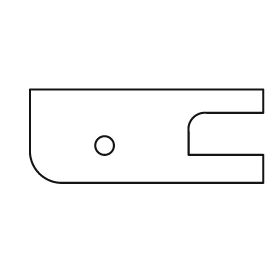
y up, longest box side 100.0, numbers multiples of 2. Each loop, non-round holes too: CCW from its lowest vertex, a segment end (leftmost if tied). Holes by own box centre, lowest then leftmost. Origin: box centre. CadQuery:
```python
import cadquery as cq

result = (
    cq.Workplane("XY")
    .moveTo(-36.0, -20.0)
    .lineTo(50.0, -20.0)
    .lineTo(50.0, -8.0)
    .lineTo(18.0, -8.0)
    .lineTo(18.0, 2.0)
    .threePointArc((20.0, 8.0), (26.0, 10.0))
    .lineTo(50.0, 10.0)
    .lineTo(50.0, 20.0)
    .lineTo(-50.0, 20.0)
    .lineTo(-50.0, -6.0)
    .threePointArc((-46.0, -16.0), (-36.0, -20.0))
    .close()
    .moveTo(-18.0, -4.0)
    .circle(4.0)
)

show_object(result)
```